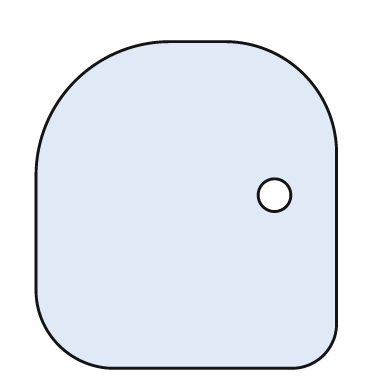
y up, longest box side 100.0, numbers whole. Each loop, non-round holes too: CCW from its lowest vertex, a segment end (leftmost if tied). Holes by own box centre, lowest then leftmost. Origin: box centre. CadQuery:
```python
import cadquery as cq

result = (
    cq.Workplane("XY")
    .moveTo(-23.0, -50.0)
    .lineTo(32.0, -50.0)
    .threePointArc((42.0, -46.0), (46.0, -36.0))
    .lineTo(46.0, 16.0)
    .threePointArc((36.0, 40.0), (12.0, 50.0))
    .lineTo(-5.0, 50.0)
    .threePointArc((-34.0, 38.0), (-46.0, 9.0))
    .lineTo(-46.0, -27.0)
    .threePointArc((-39.0, -43.0), (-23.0, -50.0))
    .close()
    .moveTo(27.0, 3.0)
    .circle(5.0)
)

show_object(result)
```